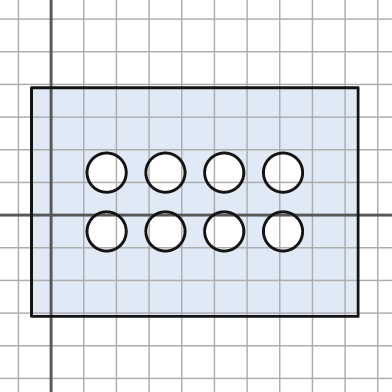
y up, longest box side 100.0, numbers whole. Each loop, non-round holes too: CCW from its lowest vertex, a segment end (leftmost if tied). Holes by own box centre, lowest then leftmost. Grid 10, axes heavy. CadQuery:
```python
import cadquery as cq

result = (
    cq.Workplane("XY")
    .moveTo(-6.0, -31.0)
    .lineTo(94.0, -31.0)
    .lineTo(94.0, 39.0)
    .lineTo(-6.0, 39.0)
    .close()
    .moveTo(17.0, -5.0)
    .circle(6.0)
    .moveTo(35.0, -5.0)
    .circle(6.0)
    .moveTo(53.0, -5.0)
    .circle(6.0)
    .moveTo(71.0, -5.0)
    .circle(6.0)
    .moveTo(17.0, 13.0)
    .circle(6.0)
    .moveTo(35.0, 13.0)
    .circle(6.0)
    .moveTo(53.0, 13.0)
    .circle(6.0)
    .moveTo(71.0, 13.0)
    .circle(6.0)
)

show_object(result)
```